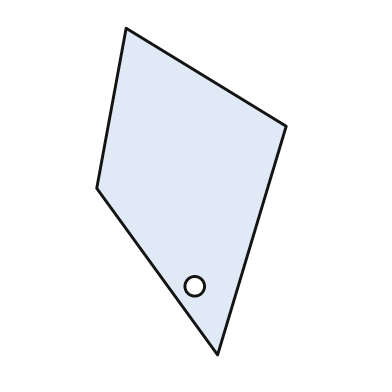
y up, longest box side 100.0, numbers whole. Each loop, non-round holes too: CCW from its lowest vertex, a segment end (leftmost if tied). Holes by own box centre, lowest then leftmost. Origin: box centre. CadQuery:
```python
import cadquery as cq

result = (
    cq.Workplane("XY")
    .moveTo(8.0, -50.0)
    .lineTo(29.0, 20.0)
    .lineTo(-20.0, 50.0)
    .lineTo(-29.0, 1.0)
    .close()
    .moveTo(1.0, -29.0)
    .circle(3.0)
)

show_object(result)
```